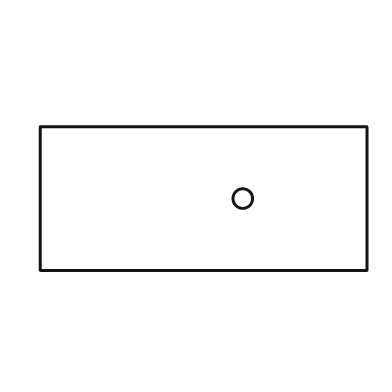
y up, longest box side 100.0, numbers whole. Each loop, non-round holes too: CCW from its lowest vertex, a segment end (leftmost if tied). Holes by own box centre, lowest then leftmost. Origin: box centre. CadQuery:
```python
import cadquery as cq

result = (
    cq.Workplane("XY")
    .moveTo(-50.0, -22.0)
    .lineTo(50.0, -22.0)
    .lineTo(50.0, 22.0)
    .lineTo(-50.0, 22.0)
    .close()
    .moveTo(12.0, 0.0)
    .circle(3.0)
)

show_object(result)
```